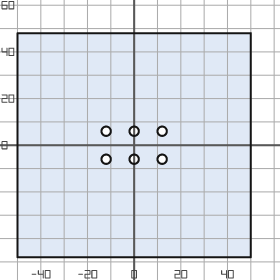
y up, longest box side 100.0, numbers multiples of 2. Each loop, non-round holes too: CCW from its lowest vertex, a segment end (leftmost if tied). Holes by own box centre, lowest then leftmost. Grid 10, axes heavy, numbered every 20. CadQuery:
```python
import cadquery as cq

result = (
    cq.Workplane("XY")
    .moveTo(-50.0, -48.0)
    .lineTo(50.0, -48.0)
    .lineTo(50.0, 48.0)
    .lineTo(-50.0, 48.0)
    .close()
    .moveTo(-12.0, -6.0)
    .circle(2.0)
    .moveTo(0.0, -6.0)
    .circle(2.0)
    .moveTo(12.0, -6.0)
    .circle(2.0)
    .moveTo(-12.0, 6.0)
    .circle(2.0)
    .moveTo(0.0, 6.0)
    .circle(2.0)
    .moveTo(12.0, 6.0)
    .circle(2.0)
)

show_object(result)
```